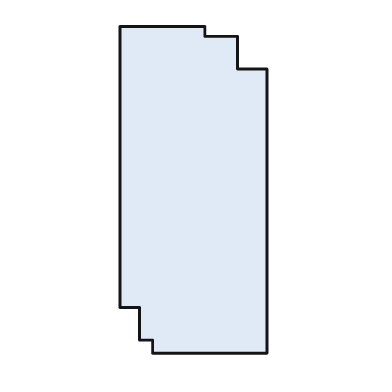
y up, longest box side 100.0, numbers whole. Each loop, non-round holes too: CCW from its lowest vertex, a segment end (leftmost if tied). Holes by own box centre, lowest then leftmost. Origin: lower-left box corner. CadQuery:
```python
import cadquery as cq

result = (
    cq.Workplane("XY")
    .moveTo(10.0, 0.0)
    .lineTo(45.0, 0.0)
    .lineTo(45.0, 87.0)
    .lineTo(36.0, 87.0)
    .lineTo(36.0, 97.0)
    .lineTo(26.0, 97.0)
    .lineTo(26.0, 100.0)
    .lineTo(0.0, 100.0)
    .lineTo(0.0, 14.0)
    .lineTo(6.0, 14.0)
    .lineTo(6.0, 4.0)
    .lineTo(10.0, 4.0)
    .close()
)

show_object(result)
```